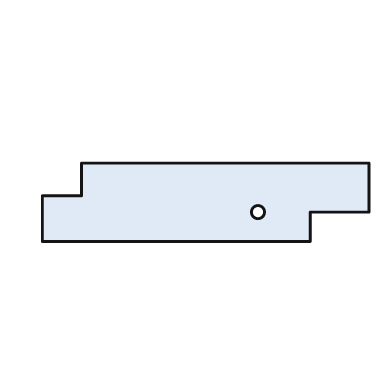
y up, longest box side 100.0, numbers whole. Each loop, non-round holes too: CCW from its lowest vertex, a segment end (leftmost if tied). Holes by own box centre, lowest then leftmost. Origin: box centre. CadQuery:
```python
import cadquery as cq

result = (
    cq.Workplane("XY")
    .moveTo(-50.0, -12.0)
    .lineTo(32.0, -12.0)
    .lineTo(32.0, -3.0)
    .lineTo(50.0, -3.0)
    .lineTo(50.0, 12.0)
    .lineTo(-38.0, 12.0)
    .lineTo(-38.0, 2.0)
    .lineTo(-50.0, 2.0)
    .close()
    .moveTo(16.0, -3.0)
    .circle(2.0)
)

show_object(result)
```